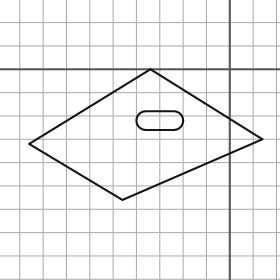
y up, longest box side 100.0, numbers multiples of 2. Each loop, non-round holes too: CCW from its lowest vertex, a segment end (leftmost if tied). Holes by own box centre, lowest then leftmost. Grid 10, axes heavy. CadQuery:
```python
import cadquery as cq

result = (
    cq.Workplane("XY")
    .moveTo(-46.0, -56.0)
    .lineTo(14.0, -30.0)
    .lineTo(-34.0, 0.0)
    .lineTo(-86.0, -32.0)
    .close()
    .moveTo(-36.0, -26.0)
    .lineTo(-24.0, -26.0)
    .threePointArc((-20.0, -22.0), (-24.0, -18.0))
    .lineTo(-36.0, -18.0)
    .threePointArc((-40.0, -22.0), (-36.0, -26.0))
    .close()
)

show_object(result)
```